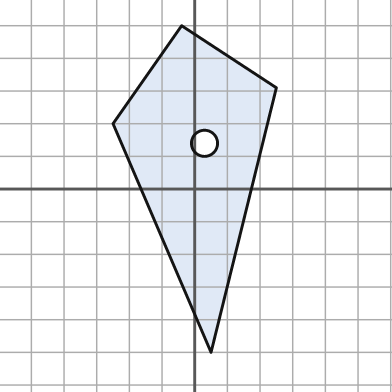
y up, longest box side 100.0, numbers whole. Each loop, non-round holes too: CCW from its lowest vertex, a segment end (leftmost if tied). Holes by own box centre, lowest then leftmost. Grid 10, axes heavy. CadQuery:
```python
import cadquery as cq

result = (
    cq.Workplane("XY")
    .moveTo(5.0, -50.0)
    .lineTo(25.0, 31.0)
    .lineTo(-4.0, 50.0)
    .lineTo(-25.0, 20.0)
    .close()
    .moveTo(3.0, 14.0)
    .circle(4.0)
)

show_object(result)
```